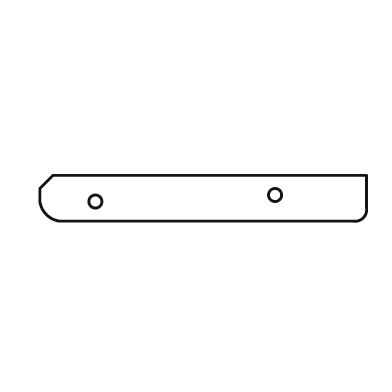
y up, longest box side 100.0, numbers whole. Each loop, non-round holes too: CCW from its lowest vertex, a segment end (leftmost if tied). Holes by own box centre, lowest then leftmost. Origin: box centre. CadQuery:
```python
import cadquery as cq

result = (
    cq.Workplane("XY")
    .moveTo(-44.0, -7.0)
    .lineTo(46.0, -7.0)
    .threePointArc((49.0, -6.0), (50.0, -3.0))
    .lineTo(50.0, 7.0)
    .lineTo(-46.0, 7.0)
    .lineTo(-50.0, 3.0)
    .lineTo(-50.0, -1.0)
    .threePointArc((-48.0, -5.0), (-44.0, -7.0))
    .close()
    .moveTo(-33.0, -1.0)
    .circle(2.0)
    .moveTo(22.0, 1.0)
    .circle(2.0)
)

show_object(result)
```